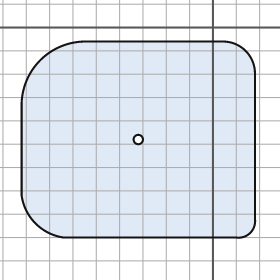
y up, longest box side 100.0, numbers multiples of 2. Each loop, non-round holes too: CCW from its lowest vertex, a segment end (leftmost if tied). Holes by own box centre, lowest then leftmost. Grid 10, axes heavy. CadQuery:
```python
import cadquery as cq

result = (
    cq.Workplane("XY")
    .moveTo(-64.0, -90.0)
    .lineTo(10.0, -90.0)
    .threePointArc((16.0, -88.0), (18.0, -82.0))
    .lineTo(18.0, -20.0)
    .threePointArc((14.0, -10.0), (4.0, -6.0))
    .lineTo(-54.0, -6.0)
    .threePointArc((-74.0, -14.0), (-82.0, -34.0))
    .lineTo(-82.0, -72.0)
    .threePointArc((-76.0, -84.0), (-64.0, -90.0))
    .close()
    .moveTo(-32.0, -48.0)
    .circle(2.0)
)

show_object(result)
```